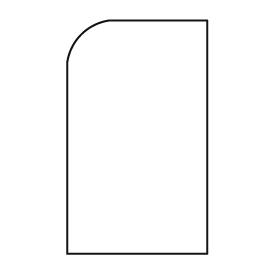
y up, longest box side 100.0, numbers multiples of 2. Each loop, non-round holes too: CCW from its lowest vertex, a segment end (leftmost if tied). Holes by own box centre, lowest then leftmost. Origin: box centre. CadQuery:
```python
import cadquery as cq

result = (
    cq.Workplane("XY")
    .moveTo(-30.0, -50.0)
    .lineTo(30.0, -50.0)
    .lineTo(30.0, 50.0)
    .lineTo(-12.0, 50.0)
    .threePointArc((-24.0, 44.0), (-30.0, 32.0))
    .close()
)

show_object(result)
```